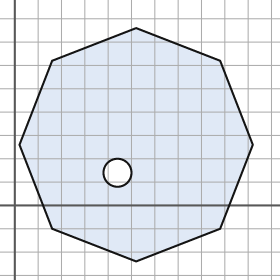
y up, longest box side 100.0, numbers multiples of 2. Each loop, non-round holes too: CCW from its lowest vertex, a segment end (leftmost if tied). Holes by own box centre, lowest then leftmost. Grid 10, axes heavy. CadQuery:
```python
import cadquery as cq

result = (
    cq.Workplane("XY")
    .moveTo(52.0, -24.0)
    .lineTo(88.0, -10.0)
    .lineTo(102.0, 26.0)
    .lineTo(88.0, 62.0)
    .lineTo(52.0, 76.0)
    .lineTo(16.0, 62.0)
    .lineTo(2.0, 26.0)
    .lineTo(16.0, -10.0)
    .close()
    .moveTo(44.0, 14.0)
    .circle(6.0)
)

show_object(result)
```